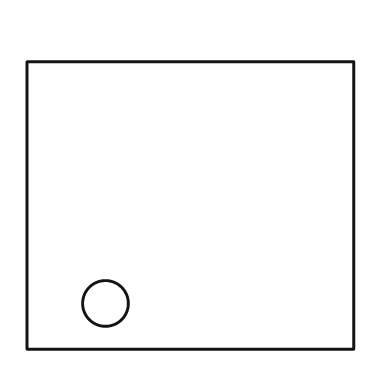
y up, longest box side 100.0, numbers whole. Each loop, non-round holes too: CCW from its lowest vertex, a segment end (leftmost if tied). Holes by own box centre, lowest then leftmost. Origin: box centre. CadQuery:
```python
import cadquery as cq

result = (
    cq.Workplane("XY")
    .moveTo(-50.0, -44.0)
    .lineTo(50.0, -44.0)
    .lineTo(50.0, 44.0)
    .lineTo(-50.0, 44.0)
    .close()
    .moveTo(-26.0, -30.0)
    .circle(7.0)
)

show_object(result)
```